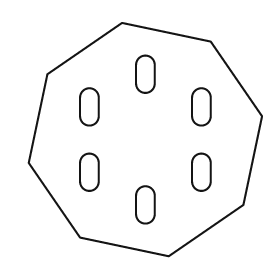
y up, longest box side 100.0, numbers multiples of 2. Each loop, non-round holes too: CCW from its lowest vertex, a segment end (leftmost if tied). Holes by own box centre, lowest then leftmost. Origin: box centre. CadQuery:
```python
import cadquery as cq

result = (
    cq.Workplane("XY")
    .moveTo(10.0, -50.0)
    .lineTo(42.0, -28.0)
    .lineTo(50.0, 10.0)
    .lineTo(28.0, 42.0)
    .lineTo(-10.0, 50.0)
    .lineTo(-42.0, 28.0)
    .lineTo(-50.0, -10.0)
    .lineTo(-28.0, -42.0)
    .close()
    .moveTo(-4.0, -32.0)
    .threePointArc((0.0, -36.0), (4.0, -32.0))
    .lineTo(4.0, -24.0)
    .threePointArc((0.0, -20.0), (-4.0, -24.0))
    .close()
    .moveTo(-28.0, -18.0)
    .threePointArc((-24.0, -22.0), (-20.0, -18.0))
    .lineTo(-20.0, -10.0)
    .threePointArc((-24.0, -6.0), (-28.0, -10.0))
    .close()
    .moveTo(20.0, -18.0)
    .threePointArc((24.0, -22.0), (28.0, -18.0))
    .lineTo(28.0, -10.0)
    .threePointArc((24.0, -6.0), (20.0, -10.0))
    .close()
    .moveTo(-28.0, 10.0)
    .threePointArc((-24.0, 6.0), (-20.0, 10.0))
    .lineTo(-20.0, 18.0)
    .threePointArc((-24.0, 22.0), (-28.0, 18.0))
    .close()
    .moveTo(20.0, 10.0)
    .threePointArc((24.0, 6.0), (28.0, 10.0))
    .lineTo(28.0, 18.0)
    .threePointArc((24.0, 22.0), (20.0, 18.0))
    .close()
    .moveTo(-4.0, 24.0)
    .threePointArc((0.0, 20.0), (4.0, 24.0))
    .lineTo(4.0, 32.0)
    .threePointArc((0.0, 36.0), (-4.0, 32.0))
    .close()
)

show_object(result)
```